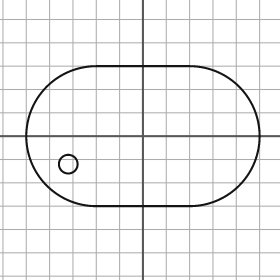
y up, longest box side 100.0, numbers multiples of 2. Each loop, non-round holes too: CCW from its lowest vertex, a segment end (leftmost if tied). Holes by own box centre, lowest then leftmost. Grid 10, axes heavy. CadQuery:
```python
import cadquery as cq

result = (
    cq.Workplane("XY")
    .moveTo(-20.0, -30.0)
    .lineTo(20.0, -30.0)
    .threePointArc((50.0, 0.0), (20.0, 30.0))
    .lineTo(-20.0, 30.0)
    .threePointArc((-50.0, 0.0), (-20.0, -30.0))
    .close()
    .moveTo(-32.0, -12.0)
    .circle(4.0)
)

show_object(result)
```